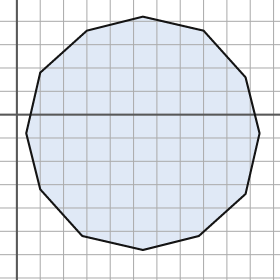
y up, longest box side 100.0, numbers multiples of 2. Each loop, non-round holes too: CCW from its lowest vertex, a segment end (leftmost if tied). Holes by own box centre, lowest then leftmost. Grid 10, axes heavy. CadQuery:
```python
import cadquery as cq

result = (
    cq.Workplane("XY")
    .moveTo(54.0, -58.0)
    .lineTo(78.0, -52.0)
    .lineTo(98.0, -34.0)
    .lineTo(104.0, -8.0)
    .lineTo(98.0, 16.0)
    .lineTo(80.0, 36.0)
    .lineTo(54.0, 42.0)
    .lineTo(30.0, 36.0)
    .lineTo(10.0, 18.0)
    .lineTo(4.0, -8.0)
    .lineTo(10.0, -32.0)
    .lineTo(28.0, -52.0)
    .close()
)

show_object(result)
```